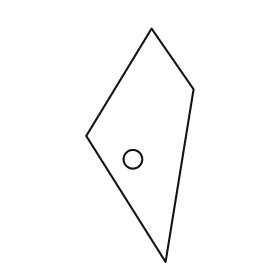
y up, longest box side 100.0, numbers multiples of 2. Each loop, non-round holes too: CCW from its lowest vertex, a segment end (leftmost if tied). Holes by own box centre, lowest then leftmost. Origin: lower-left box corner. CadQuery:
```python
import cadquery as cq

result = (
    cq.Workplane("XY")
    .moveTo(34.0, 0.0)
    .lineTo(46.0, 74.0)
    .lineTo(28.0, 100.0)
    .lineTo(0.0, 54.0)
    .close()
    .moveTo(20.0, 44.0)
    .circle(4.0)
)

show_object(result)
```